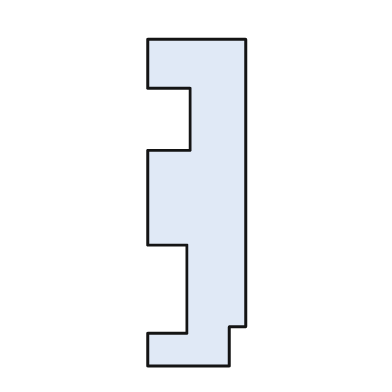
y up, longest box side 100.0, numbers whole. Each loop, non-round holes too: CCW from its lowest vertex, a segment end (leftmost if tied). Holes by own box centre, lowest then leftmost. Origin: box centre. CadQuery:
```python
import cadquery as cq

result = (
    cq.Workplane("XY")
    .moveTo(-15.0, -50.0)
    .lineTo(10.0, -50.0)
    .lineTo(10.0, -38.0)
    .lineTo(15.0, -38.0)
    .lineTo(15.0, 50.0)
    .lineTo(-15.0, 50.0)
    .lineTo(-15.0, 35.0)
    .lineTo(-2.0, 35.0)
    .lineTo(-2.0, 16.0)
    .lineTo(-15.0, 16.0)
    .lineTo(-15.0, -13.0)
    .lineTo(-3.0, -13.0)
    .lineTo(-3.0, -40.0)
    .lineTo(-15.0, -40.0)
    .close()
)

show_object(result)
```